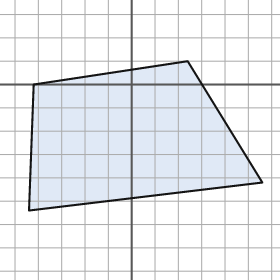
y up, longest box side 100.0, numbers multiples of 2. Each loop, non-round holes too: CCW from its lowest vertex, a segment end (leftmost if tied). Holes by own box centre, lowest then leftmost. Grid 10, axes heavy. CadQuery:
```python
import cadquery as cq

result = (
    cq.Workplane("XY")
    .moveTo(-44.0, -54.0)
    .lineTo(56.0, -42.0)
    .lineTo(24.0, 10.0)
    .lineTo(-42.0, 0.0)
    .close()
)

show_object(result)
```